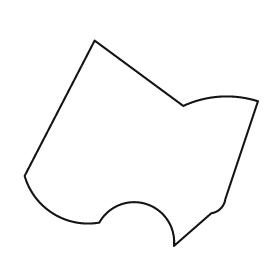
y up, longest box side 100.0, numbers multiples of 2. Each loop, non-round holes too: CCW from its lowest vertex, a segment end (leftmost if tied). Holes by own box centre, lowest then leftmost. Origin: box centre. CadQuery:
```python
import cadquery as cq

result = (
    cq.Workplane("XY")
    .moveTo(14.0, -44.0)
    .lineTo(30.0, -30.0)
    .threePointArc((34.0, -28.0), (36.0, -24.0))
    .lineTo(50.0, 18.0)
    .threePointArc((34.0, 20.0), (18.0, 16.0))
    .lineTo(-20.0, 44.0)
    .lineTo(-50.0, -14.0)
    .threePointArc((-38.0, -30.0), (-18.0, -34.0))
    .threePointArc((2.0, -26.0), (14.0, -44.0))
    .close()
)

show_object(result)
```